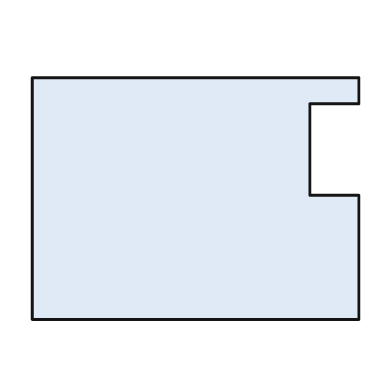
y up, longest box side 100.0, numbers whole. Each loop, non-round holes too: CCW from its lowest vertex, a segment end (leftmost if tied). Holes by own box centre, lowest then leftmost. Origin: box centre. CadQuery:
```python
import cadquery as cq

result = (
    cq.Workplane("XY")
    .moveTo(-50.0, -37.0)
    .lineTo(50.0, -37.0)
    .lineTo(50.0, 1.0)
    .lineTo(35.0, 1.0)
    .lineTo(35.0, 29.0)
    .lineTo(50.0, 29.0)
    .lineTo(50.0, 37.0)
    .lineTo(-50.0, 37.0)
    .close()
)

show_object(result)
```